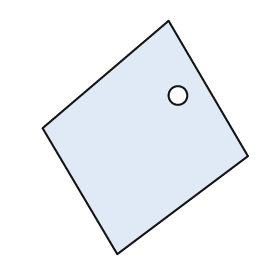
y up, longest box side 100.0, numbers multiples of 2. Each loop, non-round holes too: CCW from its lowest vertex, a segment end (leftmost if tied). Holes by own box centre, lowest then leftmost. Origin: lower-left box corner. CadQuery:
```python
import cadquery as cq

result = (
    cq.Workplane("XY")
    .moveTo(32.0, 0.0)
    .lineTo(88.0, 42.0)
    .lineTo(54.0, 100.0)
    .lineTo(0.0, 54.0)
    .close()
    .moveTo(58.0, 68.0)
    .circle(4.0)
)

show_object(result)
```